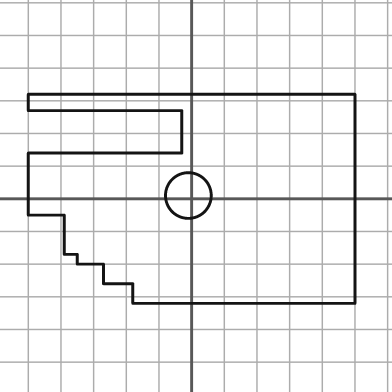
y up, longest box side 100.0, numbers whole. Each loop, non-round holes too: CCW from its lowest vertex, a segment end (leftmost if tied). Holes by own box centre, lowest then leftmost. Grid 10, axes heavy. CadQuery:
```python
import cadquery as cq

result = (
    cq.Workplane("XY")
    .moveTo(-18.0, -32.0)
    .lineTo(50.0, -32.0)
    .lineTo(50.0, 32.0)
    .lineTo(-50.0, 32.0)
    .lineTo(-50.0, 27.0)
    .lineTo(-3.0, 27.0)
    .lineTo(-3.0, 14.0)
    .lineTo(-50.0, 14.0)
    .lineTo(-50.0, -5.0)
    .lineTo(-39.0, -5.0)
    .lineTo(-39.0, -17.0)
    .lineTo(-35.0, -17.0)
    .lineTo(-35.0, -20.0)
    .lineTo(-27.0, -20.0)
    .lineTo(-27.0, -26.0)
    .lineTo(-18.0, -26.0)
    .close()
    .moveTo(-1.0, 1.0)
    .circle(7.0)
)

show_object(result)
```